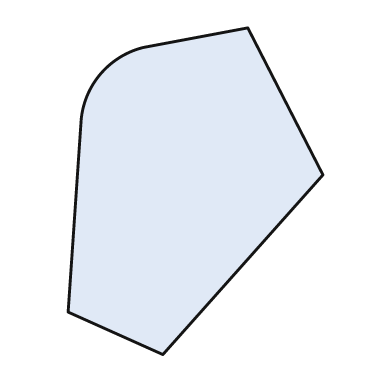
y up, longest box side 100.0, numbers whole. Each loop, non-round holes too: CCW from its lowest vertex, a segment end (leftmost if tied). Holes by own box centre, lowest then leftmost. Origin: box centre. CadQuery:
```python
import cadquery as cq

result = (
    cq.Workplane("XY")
    .moveTo(-10.0, -50.0)
    .lineTo(39.0, 5.0)
    .lineTo(16.0, 50.0)
    .lineTo(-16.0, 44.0)
    .threePointArc((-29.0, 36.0), (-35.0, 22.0))
    .lineTo(-39.0, -37.0)
    .close()
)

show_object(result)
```